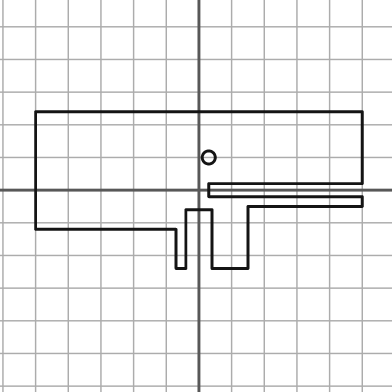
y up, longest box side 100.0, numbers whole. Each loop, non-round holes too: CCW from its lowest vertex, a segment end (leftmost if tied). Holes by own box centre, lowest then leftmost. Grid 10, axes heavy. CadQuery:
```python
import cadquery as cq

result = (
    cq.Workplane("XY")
    .moveTo(-7.0, -24.0)
    .lineTo(-4.0, -24.0)
    .lineTo(-4.0, -6.0)
    .lineTo(4.0, -6.0)
    .lineTo(4.0, -24.0)
    .lineTo(15.0, -24.0)
    .lineTo(15.0, -5.0)
    .lineTo(50.0, -5.0)
    .lineTo(50.0, -2.0)
    .lineTo(3.0, -2.0)
    .lineTo(3.0, 2.0)
    .lineTo(50.0, 2.0)
    .lineTo(50.0, 24.0)
    .lineTo(-50.0, 24.0)
    .lineTo(-50.0, -12.0)
    .lineTo(-7.0, -12.0)
    .close()
    .moveTo(3.0, 10.0)
    .circle(2.0)
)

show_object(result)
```